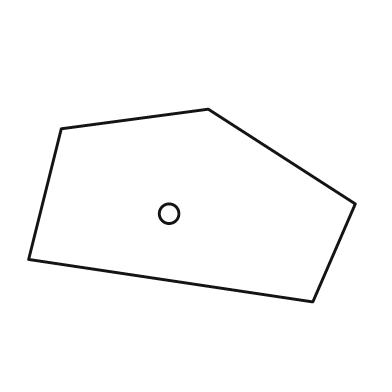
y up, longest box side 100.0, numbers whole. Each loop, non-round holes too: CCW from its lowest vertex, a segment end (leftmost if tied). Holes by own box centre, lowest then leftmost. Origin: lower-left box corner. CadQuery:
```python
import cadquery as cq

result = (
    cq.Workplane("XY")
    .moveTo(87.0, 0.0)
    .lineTo(100.0, 30.0)
    .lineTo(55.0, 59.0)
    .lineTo(10.0, 53.0)
    .lineTo(0.0, 13.0)
    .close()
    .moveTo(43.0, 27.0)
    .circle(3.0)
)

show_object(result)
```